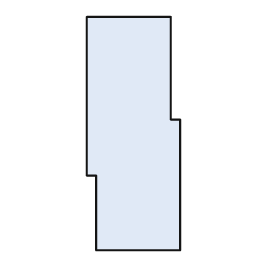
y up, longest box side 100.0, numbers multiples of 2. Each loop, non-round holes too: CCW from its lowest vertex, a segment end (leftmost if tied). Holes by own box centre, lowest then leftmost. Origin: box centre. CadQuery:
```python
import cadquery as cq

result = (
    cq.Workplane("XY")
    .moveTo(-16.0, -50.0)
    .lineTo(20.0, -50.0)
    .lineTo(20.0, 6.0)
    .lineTo(16.0, 6.0)
    .lineTo(16.0, 50.0)
    .lineTo(-20.0, 50.0)
    .lineTo(-20.0, -18.0)
    .lineTo(-16.0, -18.0)
    .close()
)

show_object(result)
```